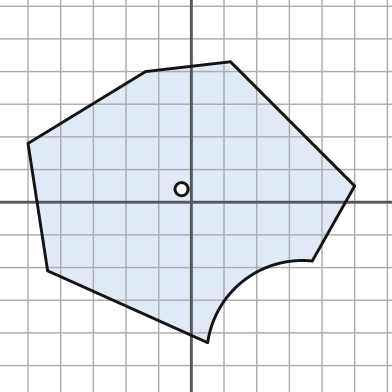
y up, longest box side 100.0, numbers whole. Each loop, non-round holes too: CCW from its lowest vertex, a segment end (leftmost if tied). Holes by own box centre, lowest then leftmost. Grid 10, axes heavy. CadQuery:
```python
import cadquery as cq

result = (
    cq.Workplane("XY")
    .moveTo(5.0, -43.0)
    .threePointArc((16.0, -24.0), (37.0, -18.0))
    .lineTo(50.0, 5.0)
    .lineTo(12.0, 43.0)
    .lineTo(-14.0, 40.0)
    .lineTo(-50.0, 18.0)
    .lineTo(-44.0, -21.0)
    .close()
    .moveTo(-3.0, 4.0)
    .circle(2.0)
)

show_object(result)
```